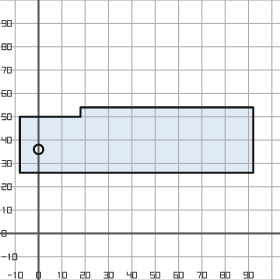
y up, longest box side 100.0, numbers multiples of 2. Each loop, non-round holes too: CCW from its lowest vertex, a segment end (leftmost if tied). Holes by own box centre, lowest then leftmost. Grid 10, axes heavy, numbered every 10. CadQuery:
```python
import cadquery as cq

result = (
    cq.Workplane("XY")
    .moveTo(-8.0, 26.0)
    .lineTo(92.0, 26.0)
    .lineTo(92.0, 54.0)
    .lineTo(18.0, 54.0)
    .lineTo(18.0, 50.0)
    .lineTo(-8.0, 50.0)
    .close()
    .moveTo(0.0, 36.0)
    .circle(2.0)
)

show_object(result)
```